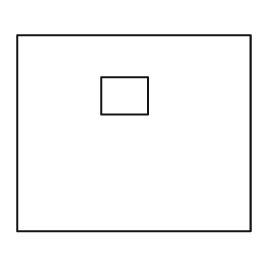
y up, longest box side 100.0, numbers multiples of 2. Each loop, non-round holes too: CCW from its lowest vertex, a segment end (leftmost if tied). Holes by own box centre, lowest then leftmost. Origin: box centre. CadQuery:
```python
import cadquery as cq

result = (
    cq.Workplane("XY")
    .moveTo(-50.0, -42.0)
    .lineTo(50.0, -42.0)
    .lineTo(50.0, 42.0)
    .lineTo(-50.0, 42.0)
    .close()
    .moveTo(-14.0, 8.0)
    .lineTo(6.0, 8.0)
    .lineTo(6.0, 24.0)
    .lineTo(-14.0, 24.0)
    .close()
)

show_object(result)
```